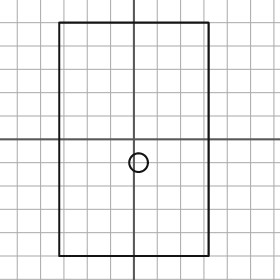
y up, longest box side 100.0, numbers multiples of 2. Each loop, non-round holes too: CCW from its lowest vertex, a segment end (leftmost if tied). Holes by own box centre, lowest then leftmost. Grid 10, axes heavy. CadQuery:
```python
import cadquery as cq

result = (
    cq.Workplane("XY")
    .moveTo(-32.0, -50.0)
    .lineTo(32.0, -50.0)
    .lineTo(32.0, 50.0)
    .lineTo(-32.0, 50.0)
    .close()
    .moveTo(2.0, -10.0)
    .circle(4.0)
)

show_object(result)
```